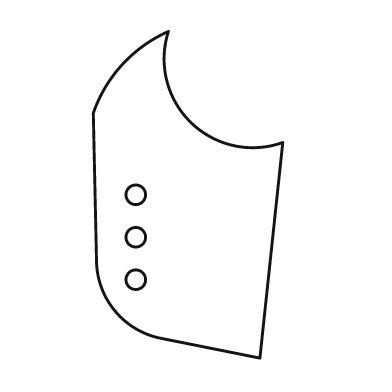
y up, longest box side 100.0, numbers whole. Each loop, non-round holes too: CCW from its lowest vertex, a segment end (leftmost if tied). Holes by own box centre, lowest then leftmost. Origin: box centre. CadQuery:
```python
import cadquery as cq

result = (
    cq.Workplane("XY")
    .moveTo(22.0, -50.0)
    .lineTo(29.0, 16.0)
    .threePointArc((1.0, 22.0), (-6.0, 50.0))
    .threePointArc((-20.0, 40.0), (-29.0, 25.0))
    .lineTo(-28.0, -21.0)
    .threePointArc((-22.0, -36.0), (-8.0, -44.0))
    .close()
    .moveTo(-16.0, -26.0)
    .circle(3.0)
    .moveTo(-16.0, -13.0)
    .circle(3.0)
    .moveTo(-16.0, 0.0)
    .circle(3.0)
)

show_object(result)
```